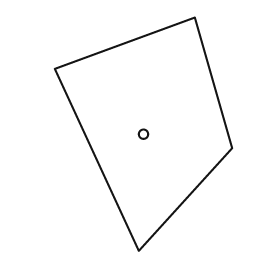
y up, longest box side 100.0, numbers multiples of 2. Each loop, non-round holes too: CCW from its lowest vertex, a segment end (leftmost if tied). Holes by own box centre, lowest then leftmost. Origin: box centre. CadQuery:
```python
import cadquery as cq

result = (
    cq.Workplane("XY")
    .moveTo(-2.0, -50.0)
    .lineTo(38.0, -6.0)
    .lineTo(22.0, 50.0)
    .lineTo(-38.0, 28.0)
    .close()
    .moveTo(0.0, 0.0)
    .circle(2.0)
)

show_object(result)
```